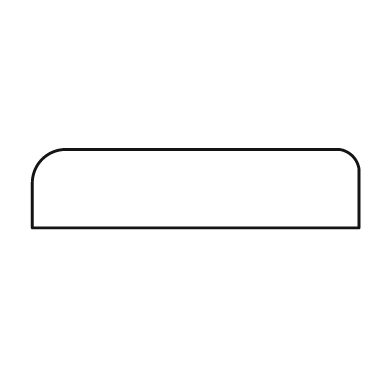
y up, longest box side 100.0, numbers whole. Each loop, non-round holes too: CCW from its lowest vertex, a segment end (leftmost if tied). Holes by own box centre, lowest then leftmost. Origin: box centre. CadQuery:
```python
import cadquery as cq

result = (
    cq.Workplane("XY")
    .moveTo(-50.0, -12.0)
    .lineTo(50.0, -12.0)
    .lineTo(50.0, 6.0)
    .threePointArc((48.0, 10.0), (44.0, 12.0))
    .lineTo(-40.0, 12.0)
    .threePointArc((-47.0, 9.0), (-50.0, 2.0))
    .close()
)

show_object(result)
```